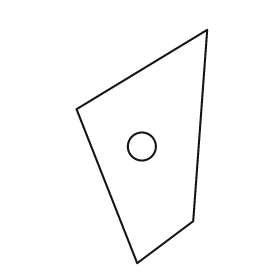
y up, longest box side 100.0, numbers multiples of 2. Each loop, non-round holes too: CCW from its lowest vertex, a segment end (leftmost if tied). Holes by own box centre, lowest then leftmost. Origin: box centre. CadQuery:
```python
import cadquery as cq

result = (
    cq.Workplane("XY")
    .moveTo(-2.0, -50.0)
    .lineTo(22.0, -32.0)
    .lineTo(28.0, 50.0)
    .lineTo(-28.0, 16.0)
    .close()
    .moveTo(0.0, 0.0)
    .circle(6.0)
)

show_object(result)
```